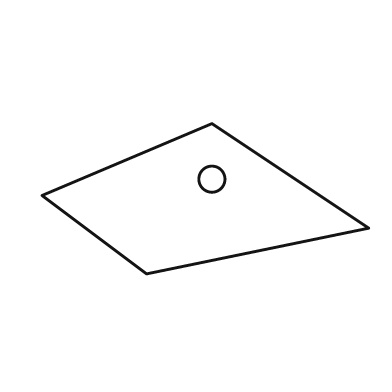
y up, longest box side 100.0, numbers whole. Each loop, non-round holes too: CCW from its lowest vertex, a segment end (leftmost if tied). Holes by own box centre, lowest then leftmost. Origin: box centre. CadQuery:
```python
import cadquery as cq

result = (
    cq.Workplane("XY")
    .moveTo(-18.0, -23.0)
    .lineTo(50.0, -9.0)
    .lineTo(2.0, 23.0)
    .lineTo(-50.0, 1.0)
    .close()
    .moveTo(2.0, 6.0)
    .circle(4.0)
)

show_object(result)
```